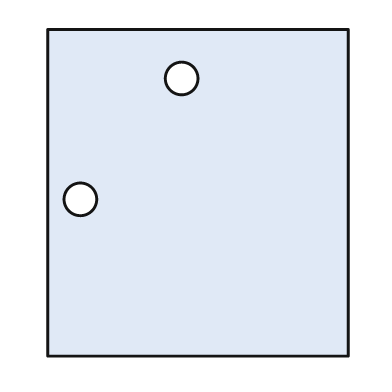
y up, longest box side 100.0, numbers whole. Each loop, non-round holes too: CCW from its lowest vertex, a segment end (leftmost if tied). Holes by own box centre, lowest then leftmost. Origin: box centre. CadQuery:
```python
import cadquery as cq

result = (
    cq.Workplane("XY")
    .moveTo(-46.0, -50.0)
    .lineTo(46.0, -50.0)
    .lineTo(46.0, 50.0)
    .lineTo(-46.0, 50.0)
    .close()
    .moveTo(-36.0, -2.0)
    .circle(5.0)
    .moveTo(-5.0, 35.0)
    .circle(5.0)
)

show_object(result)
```